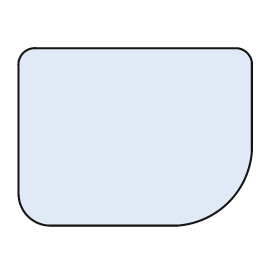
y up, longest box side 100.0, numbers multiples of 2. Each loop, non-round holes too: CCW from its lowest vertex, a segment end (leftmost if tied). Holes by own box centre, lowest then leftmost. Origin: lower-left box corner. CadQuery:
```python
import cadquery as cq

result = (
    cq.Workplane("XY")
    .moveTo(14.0, 0.0)
    .lineTo(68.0, 0.0)
    .threePointArc((90.0, 10.0), (100.0, 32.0))
    .lineTo(100.0, 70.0)
    .threePointArc((98.0, 74.0), (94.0, 76.0))
    .lineTo(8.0, 76.0)
    .threePointArc((2.0, 74.0), (0.0, 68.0))
    .lineTo(0.0, 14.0)
    .threePointArc((4.0, 4.0), (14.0, 0.0))
    .close()
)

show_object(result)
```